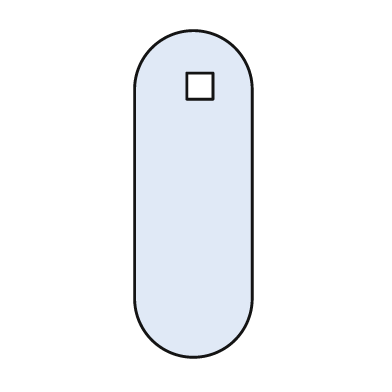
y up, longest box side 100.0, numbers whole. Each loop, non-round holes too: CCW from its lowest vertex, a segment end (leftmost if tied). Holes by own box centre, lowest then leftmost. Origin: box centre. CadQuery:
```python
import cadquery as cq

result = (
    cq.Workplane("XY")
    .moveTo(-18.0, -32.0)
    .threePointArc((0.0, -50.0), (18.0, -32.0))
    .lineTo(18.0, 32.0)
    .threePointArc((0.0, 50.0), (-18.0, 32.0))
    .close()
    .moveTo(-2.0, 29.0)
    .lineTo(6.0, 29.0)
    .lineTo(6.0, 37.0)
    .lineTo(-2.0, 37.0)
    .close()
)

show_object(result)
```